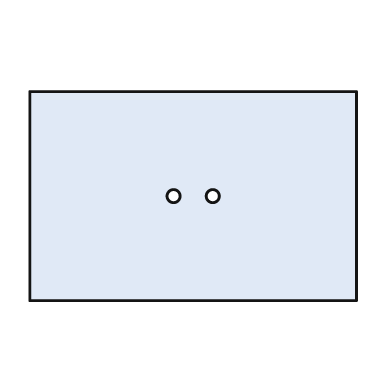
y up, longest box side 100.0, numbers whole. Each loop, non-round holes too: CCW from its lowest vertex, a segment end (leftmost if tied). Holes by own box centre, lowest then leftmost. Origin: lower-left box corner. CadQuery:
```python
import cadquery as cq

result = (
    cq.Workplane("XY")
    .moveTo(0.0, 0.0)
    .lineTo(100.0, 0.0)
    .lineTo(100.0, 64.0)
    .lineTo(0.0, 64.0)
    .close()
    .moveTo(44.0, 32.0)
    .circle(2.0)
    .moveTo(56.0, 32.0)
    .circle(2.0)
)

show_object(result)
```